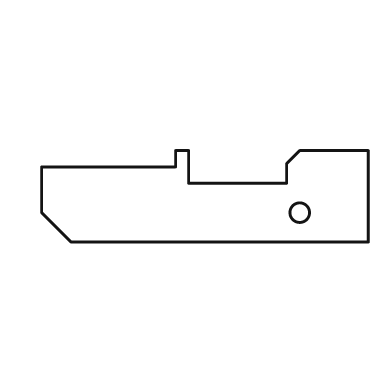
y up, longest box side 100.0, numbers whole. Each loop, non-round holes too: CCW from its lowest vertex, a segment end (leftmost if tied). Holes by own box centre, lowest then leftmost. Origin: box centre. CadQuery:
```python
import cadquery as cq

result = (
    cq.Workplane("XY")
    .moveTo(-41.0, -14.0)
    .lineTo(50.0, -14.0)
    .lineTo(50.0, 14.0)
    .lineTo(29.0, 14.0)
    .lineTo(25.0, 10.0)
    .lineTo(25.0, 4.0)
    .lineTo(-5.0, 4.0)
    .lineTo(-5.0, 14.0)
    .lineTo(-9.0, 14.0)
    .lineTo(-9.0, 9.0)
    .lineTo(-50.0, 9.0)
    .lineTo(-50.0, -5.0)
    .close()
    .moveTo(29.0, -5.0)
    .circle(3.0)
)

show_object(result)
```